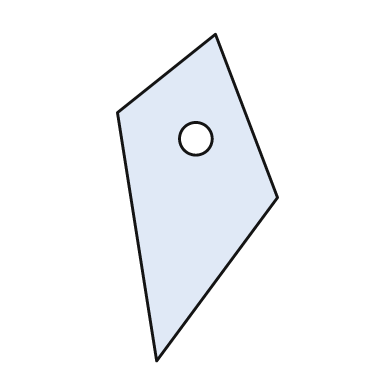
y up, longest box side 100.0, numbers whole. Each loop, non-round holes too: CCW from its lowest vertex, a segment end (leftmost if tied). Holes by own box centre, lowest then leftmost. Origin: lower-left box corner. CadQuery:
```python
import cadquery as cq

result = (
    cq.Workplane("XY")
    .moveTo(12.0, 0.0)
    .lineTo(49.0, 50.0)
    .lineTo(30.0, 100.0)
    .lineTo(0.0, 76.0)
    .close()
    .moveTo(24.0, 68.0)
    .circle(5.0)
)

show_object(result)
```